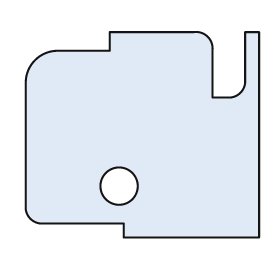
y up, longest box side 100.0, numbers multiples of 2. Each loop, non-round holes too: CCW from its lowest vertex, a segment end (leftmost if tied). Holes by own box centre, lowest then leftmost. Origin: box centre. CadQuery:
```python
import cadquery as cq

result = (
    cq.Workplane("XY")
    .moveTo(-8.0, -44.0)
    .lineTo(50.0, -44.0)
    .lineTo(50.0, 44.0)
    .lineTo(44.0, 44.0)
    .lineTo(44.0, 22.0)
    .threePointArc((42.0, 18.0), (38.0, 16.0))
    .lineTo(30.0, 16.0)
    .lineTo(30.0, 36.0)
    .threePointArc((28.0, 42.0), (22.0, 44.0))
    .lineTo(-14.0, 44.0)
    .lineTo(-14.0, 36.0)
    .lineTo(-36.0, 36.0)
    .threePointArc((-46.0, 32.0), (-50.0, 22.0))
    .lineTo(-50.0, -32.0)
    .threePointArc((-48.0, -36.0), (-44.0, -38.0))
    .lineTo(-8.0, -38.0)
    .close()
    .moveTo(-10.0, -22.0)
    .circle(8.0)
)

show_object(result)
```